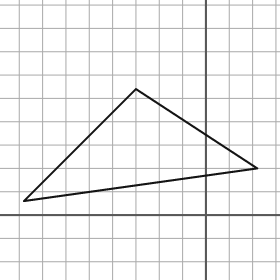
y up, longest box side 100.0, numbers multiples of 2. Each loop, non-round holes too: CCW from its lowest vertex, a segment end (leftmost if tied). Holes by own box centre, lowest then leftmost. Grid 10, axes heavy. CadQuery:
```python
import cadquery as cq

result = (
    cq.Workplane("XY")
    .moveTo(-78.0, 6.0)
    .lineTo(22.0, 20.0)
    .lineTo(-30.0, 54.0)
    .close()
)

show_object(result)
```